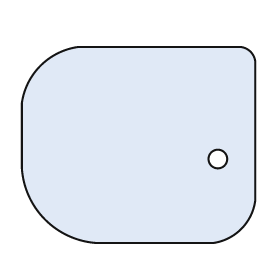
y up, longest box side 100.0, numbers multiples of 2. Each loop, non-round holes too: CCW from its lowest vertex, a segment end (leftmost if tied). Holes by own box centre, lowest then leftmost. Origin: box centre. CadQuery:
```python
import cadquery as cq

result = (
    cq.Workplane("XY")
    .moveTo(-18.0, -42.0)
    .lineTo(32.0, -42.0)
    .threePointArc((44.0, -36.0), (50.0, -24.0))
    .lineTo(50.0, 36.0)
    .threePointArc((48.0, 40.0), (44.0, 42.0))
    .lineTo(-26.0, 42.0)
    .threePointArc((-42.0, 34.0), (-50.0, 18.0))
    .lineTo(-50.0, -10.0)
    .threePointArc((-40.0, -32.0), (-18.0, -42.0))
    .close()
    .moveTo(34.0, -6.0)
    .circle(4.0)
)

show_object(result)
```